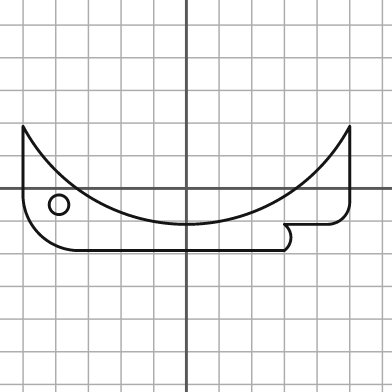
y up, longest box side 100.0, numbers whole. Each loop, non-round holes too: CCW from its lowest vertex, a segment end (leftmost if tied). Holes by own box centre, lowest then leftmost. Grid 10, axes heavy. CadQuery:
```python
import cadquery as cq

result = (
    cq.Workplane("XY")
    .moveTo(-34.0, -19.0)
    .lineTo(30.0, -19.0)
    .threePointArc((32.0, -15.0), (30.0, -11.0))
    .lineTo(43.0, -11.0)
    .threePointArc((48.0, -9.0), (50.0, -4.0))
    .lineTo(50.0, 19.0)
    .threePointArc((0.0, -11.0), (-50.0, 19.0))
    .lineTo(-50.0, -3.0)
    .threePointArc((-45.0, -14.0), (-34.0, -19.0))
    .close()
    .moveTo(-39.0, -5.0)
    .circle(3.0)
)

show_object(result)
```